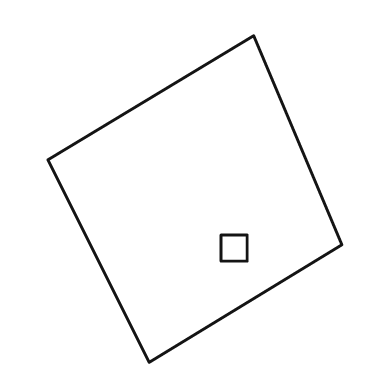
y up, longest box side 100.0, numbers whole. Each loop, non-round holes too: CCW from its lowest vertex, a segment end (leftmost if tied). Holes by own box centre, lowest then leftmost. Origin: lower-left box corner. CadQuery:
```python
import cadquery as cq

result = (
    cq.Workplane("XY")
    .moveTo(31.0, 0.0)
    .lineTo(90.0, 36.0)
    .lineTo(63.0, 100.0)
    .lineTo(0.0, 62.0)
    .close()
    .moveTo(53.0, 31.0)
    .lineTo(61.0, 31.0)
    .lineTo(61.0, 39.0)
    .lineTo(53.0, 39.0)
    .close()
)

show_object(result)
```